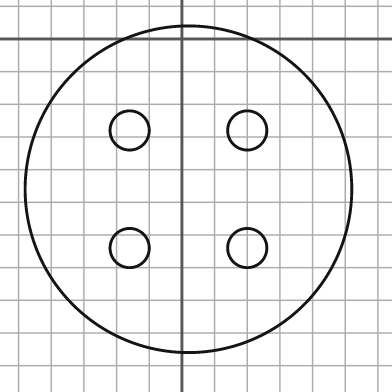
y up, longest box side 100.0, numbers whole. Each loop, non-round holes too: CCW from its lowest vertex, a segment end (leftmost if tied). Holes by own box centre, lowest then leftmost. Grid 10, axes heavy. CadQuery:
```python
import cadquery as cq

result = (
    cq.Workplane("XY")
    .moveTo(2.0, -46.0)
    .circle(50.0)
    .moveTo(-16.0, -64.0)
    .circle(6.0)
    .moveTo(20.0, -64.0)
    .circle(6.0)
    .moveTo(-16.0, -28.0)
    .circle(6.0)
    .moveTo(20.0, -28.0)
    .circle(6.0)
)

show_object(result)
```